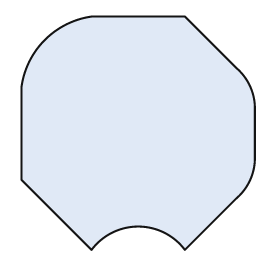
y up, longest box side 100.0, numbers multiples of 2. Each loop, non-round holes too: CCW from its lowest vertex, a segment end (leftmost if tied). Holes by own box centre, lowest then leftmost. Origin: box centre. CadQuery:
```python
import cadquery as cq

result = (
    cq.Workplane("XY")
    .moveTo(-20.0, -50.0)
    .threePointArc((0.0, -40.0), (20.0, -50.0))
    .lineTo(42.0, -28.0)
    .threePointArc((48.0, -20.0), (50.0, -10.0))
    .lineTo(50.0, 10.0)
    .threePointArc((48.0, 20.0), (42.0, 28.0))
    .lineTo(20.0, 50.0)
    .lineTo(-20.0, 50.0)
    .threePointArc((-40.0, 40.0), (-50.0, 20.0))
    .lineTo(-50.0, -20.0)
    .close()
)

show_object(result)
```